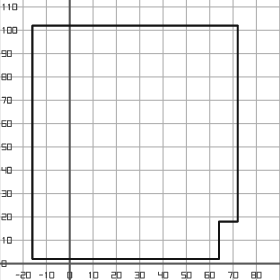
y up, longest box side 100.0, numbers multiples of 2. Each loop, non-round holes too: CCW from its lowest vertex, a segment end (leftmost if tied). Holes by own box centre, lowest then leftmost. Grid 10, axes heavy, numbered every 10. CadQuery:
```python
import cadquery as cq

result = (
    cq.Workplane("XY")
    .moveTo(-16.0, 2.0)
    .lineTo(64.0, 2.0)
    .lineTo(64.0, 18.0)
    .lineTo(72.0, 18.0)
    .lineTo(72.0, 102.0)
    .lineTo(-16.0, 102.0)
    .close()
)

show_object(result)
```